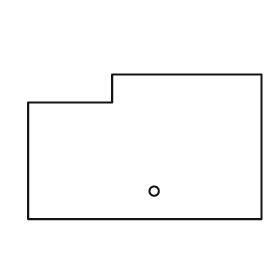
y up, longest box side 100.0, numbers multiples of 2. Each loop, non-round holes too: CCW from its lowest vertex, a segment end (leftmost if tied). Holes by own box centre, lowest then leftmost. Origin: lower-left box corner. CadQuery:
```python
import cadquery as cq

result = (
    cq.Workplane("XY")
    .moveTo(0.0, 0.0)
    .lineTo(100.0, 0.0)
    .lineTo(100.0, 62.0)
    .lineTo(36.0, 62.0)
    .lineTo(36.0, 50.0)
    .lineTo(0.0, 50.0)
    .close()
    .moveTo(54.0, 12.0)
    .circle(2.0)
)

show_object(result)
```